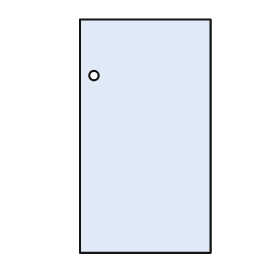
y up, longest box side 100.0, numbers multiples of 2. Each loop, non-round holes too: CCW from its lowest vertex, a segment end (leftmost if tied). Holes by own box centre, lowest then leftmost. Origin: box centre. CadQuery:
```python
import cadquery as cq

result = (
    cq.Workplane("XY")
    .moveTo(-28.0, -50.0)
    .lineTo(28.0, -50.0)
    .lineTo(28.0, 50.0)
    .lineTo(-28.0, 50.0)
    .close()
    .moveTo(-22.0, 26.0)
    .circle(2.0)
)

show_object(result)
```